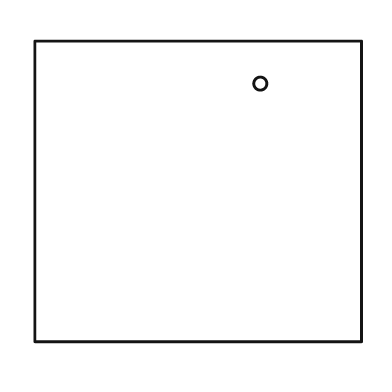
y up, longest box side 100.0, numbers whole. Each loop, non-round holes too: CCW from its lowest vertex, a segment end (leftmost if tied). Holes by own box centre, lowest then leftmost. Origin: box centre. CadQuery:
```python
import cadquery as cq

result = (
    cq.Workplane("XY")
    .moveTo(-50.0, -46.0)
    .lineTo(50.0, -46.0)
    .lineTo(50.0, 46.0)
    .lineTo(-50.0, 46.0)
    .close()
    .moveTo(19.0, 33.0)
    .circle(2.0)
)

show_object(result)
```